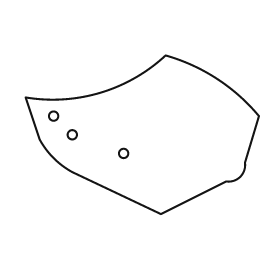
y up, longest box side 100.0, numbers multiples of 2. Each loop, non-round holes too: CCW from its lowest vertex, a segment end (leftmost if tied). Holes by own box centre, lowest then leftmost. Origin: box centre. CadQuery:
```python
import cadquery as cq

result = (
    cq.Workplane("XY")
    .moveTo(8.0, -34.0)
    .lineTo(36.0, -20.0)
    .threePointArc((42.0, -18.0), (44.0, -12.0))
    .lineTo(50.0, 8.0)
    .threePointArc((32.0, 24.0), (10.0, 34.0))
    .threePointArc((-18.0, 18.0), (-50.0, 16.0))
    .lineTo(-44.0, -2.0)
    .threePointArc((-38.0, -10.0), (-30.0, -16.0))
    .close()
    .moveTo(-8.0, -8.0)
    .circle(2.0)
    .moveTo(-30.0, 0.0)
    .circle(2.0)
    .moveTo(-38.0, 8.0)
    .circle(2.0)
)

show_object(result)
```